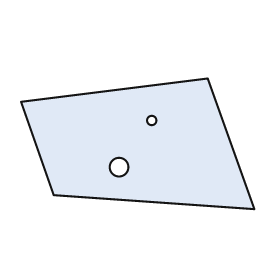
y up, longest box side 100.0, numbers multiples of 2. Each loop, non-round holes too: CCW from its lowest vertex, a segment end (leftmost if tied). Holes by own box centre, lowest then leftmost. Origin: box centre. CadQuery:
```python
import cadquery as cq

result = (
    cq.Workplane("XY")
    .moveTo(50.0, -28.0)
    .lineTo(30.0, 28.0)
    .lineTo(-50.0, 18.0)
    .lineTo(-36.0, -22.0)
    .close()
    .moveTo(-8.0, -10.0)
    .circle(4.0)
    .moveTo(6.0, 10.0)
    .circle(2.0)
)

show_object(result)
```